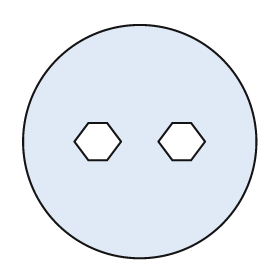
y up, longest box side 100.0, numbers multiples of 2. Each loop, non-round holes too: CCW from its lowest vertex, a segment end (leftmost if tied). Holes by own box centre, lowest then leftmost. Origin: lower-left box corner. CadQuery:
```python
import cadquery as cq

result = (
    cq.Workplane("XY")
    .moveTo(50.0, 50.0)
    .circle(50.0)
    .moveTo(28.0, 42.0)
    .lineTo(36.0, 42.0)
    .lineTo(42.0, 50.0)
    .lineTo(36.0, 58.0)
    .lineTo(28.0, 58.0)
    .lineTo(22.0, 50.0)
    .close()
    .moveTo(64.0, 42.0)
    .lineTo(72.0, 42.0)
    .lineTo(78.0, 50.0)
    .lineTo(72.0, 58.0)
    .lineTo(64.0, 58.0)
    .lineTo(58.0, 50.0)
    .close()
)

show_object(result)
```